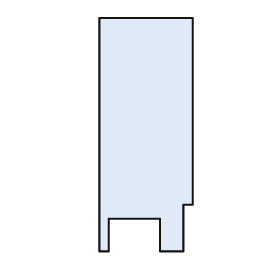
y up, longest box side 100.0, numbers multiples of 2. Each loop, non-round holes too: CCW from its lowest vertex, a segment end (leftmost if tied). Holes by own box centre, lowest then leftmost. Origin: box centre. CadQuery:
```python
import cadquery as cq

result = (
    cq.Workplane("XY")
    .moveTo(-20.0, -50.0)
    .lineTo(-16.0, -50.0)
    .lineTo(-16.0, -36.0)
    .lineTo(6.0, -36.0)
    .lineTo(6.0, -50.0)
    .lineTo(16.0, -50.0)
    .lineTo(16.0, -30.0)
    .lineTo(20.0, -30.0)
    .lineTo(20.0, 50.0)
    .lineTo(-20.0, 50.0)
    .close()
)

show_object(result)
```